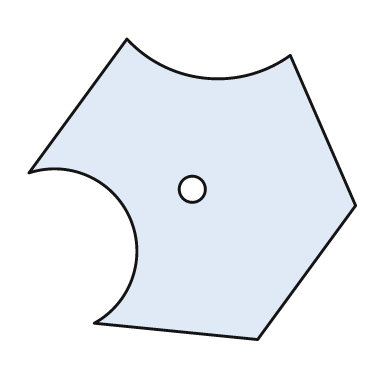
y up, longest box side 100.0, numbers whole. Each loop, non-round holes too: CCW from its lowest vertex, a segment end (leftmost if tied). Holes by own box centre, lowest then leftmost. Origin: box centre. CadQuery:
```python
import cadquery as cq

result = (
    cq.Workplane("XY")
    .moveTo(20.0, -46.0)
    .lineTo(50.0, -5.0)
    .lineTo(30.0, 41.0)
    .threePointArc((4.0, 34.0), (-20.0, 46.0))
    .lineTo(-50.0, 5.0)
    .threePointArc((-19.0, -9.0), (-30.0, -41.0))
    .close()
    .moveTo(0.0, 0.0)
    .circle(4.0)
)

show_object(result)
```